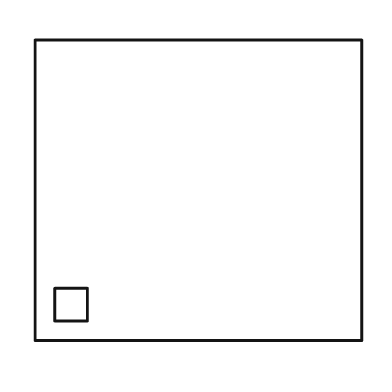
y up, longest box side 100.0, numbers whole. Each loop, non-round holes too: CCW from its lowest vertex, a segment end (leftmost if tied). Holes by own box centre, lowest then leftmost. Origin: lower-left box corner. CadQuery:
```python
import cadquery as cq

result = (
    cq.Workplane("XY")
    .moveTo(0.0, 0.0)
    .lineTo(100.0, 0.0)
    .lineTo(100.0, 92.0)
    .lineTo(0.0, 92.0)
    .close()
    .moveTo(6.0, 6.0)
    .lineTo(16.0, 6.0)
    .lineTo(16.0, 16.0)
    .lineTo(6.0, 16.0)
    .close()
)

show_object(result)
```